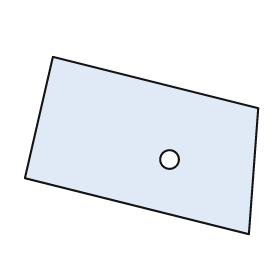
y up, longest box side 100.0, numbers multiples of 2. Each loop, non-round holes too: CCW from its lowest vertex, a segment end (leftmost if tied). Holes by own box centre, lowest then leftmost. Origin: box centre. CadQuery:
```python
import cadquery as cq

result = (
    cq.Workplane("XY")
    .moveTo(46.0, -38.0)
    .lineTo(50.0, 16.0)
    .lineTo(-38.0, 38.0)
    .lineTo(-50.0, -14.0)
    .close()
    .moveTo(12.0, -6.0)
    .circle(4.0)
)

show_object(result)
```